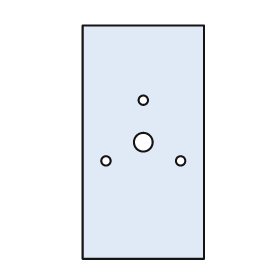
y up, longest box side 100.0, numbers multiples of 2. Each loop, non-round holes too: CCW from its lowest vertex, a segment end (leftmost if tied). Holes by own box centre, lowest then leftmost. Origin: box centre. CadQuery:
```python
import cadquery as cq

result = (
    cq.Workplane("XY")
    .moveTo(-26.0, -50.0)
    .lineTo(26.0, -50.0)
    .lineTo(26.0, 50.0)
    .lineTo(-26.0, 50.0)
    .close()
    .moveTo(-16.0, -8.0)
    .circle(2.0)
    .moveTo(16.0, -8.0)
    .circle(2.0)
    .moveTo(0.0, 0.0)
    .circle(4.0)
    .moveTo(0.0, 18.0)
    .circle(2.0)
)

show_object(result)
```